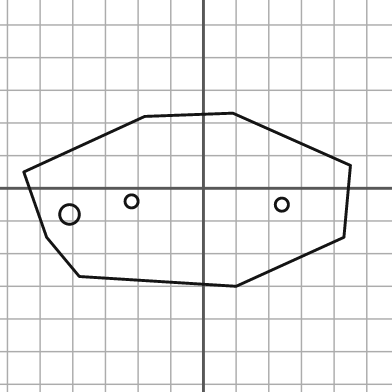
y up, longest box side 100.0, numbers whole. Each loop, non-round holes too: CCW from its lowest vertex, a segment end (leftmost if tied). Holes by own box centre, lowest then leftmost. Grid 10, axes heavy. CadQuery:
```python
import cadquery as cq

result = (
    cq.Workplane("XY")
    .moveTo(10.0, -30.0)
    .lineTo(43.0, -15.0)
    .lineTo(45.0, 7.0)
    .lineTo(9.0, 23.0)
    .lineTo(-18.0, 22.0)
    .lineTo(-55.0, 5.0)
    .lineTo(-48.0, -15.0)
    .lineTo(-38.0, -27.0)
    .close()
    .moveTo(-41.0, -8.0)
    .circle(3.0)
    .moveTo(24.0, -5.0)
    .circle(2.0)
    .moveTo(-22.0, -4.0)
    .circle(2.0)
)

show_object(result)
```